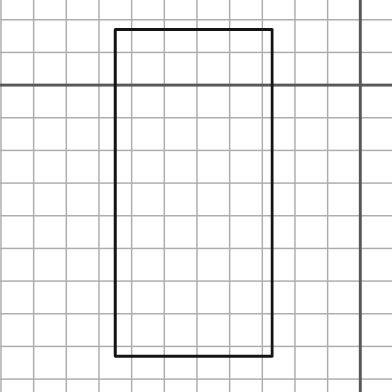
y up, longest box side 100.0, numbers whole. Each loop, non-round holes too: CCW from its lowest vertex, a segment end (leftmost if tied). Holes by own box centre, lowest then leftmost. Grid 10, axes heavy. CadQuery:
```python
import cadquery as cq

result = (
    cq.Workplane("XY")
    .moveTo(-75.0, -83.0)
    .lineTo(-27.0, -83.0)
    .lineTo(-27.0, 17.0)
    .lineTo(-75.0, 17.0)
    .close()
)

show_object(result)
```